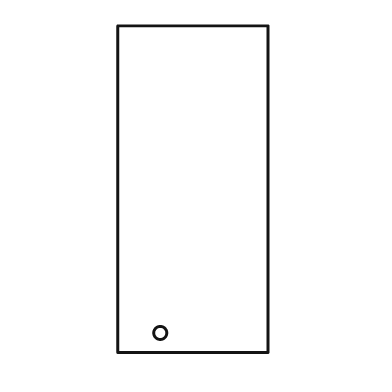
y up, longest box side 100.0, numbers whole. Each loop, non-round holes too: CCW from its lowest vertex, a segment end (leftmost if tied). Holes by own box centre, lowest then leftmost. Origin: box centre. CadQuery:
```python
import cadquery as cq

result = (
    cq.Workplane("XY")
    .moveTo(-23.0, -50.0)
    .lineTo(23.0, -50.0)
    .lineTo(23.0, 50.0)
    .lineTo(-23.0, 50.0)
    .close()
    .moveTo(-10.0, -44.0)
    .circle(2.0)
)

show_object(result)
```